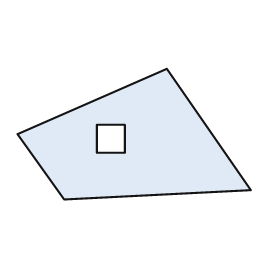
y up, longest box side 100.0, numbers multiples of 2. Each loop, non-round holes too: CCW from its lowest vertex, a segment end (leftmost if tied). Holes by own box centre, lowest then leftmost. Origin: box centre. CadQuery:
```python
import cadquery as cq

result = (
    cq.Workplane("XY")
    .moveTo(-30.0, -28.0)
    .lineTo(50.0, -24.0)
    .lineTo(14.0, 28.0)
    .lineTo(-50.0, 0.0)
    .close()
    .moveTo(-16.0, -8.0)
    .lineTo(-4.0, -8.0)
    .lineTo(-4.0, 4.0)
    .lineTo(-16.0, 4.0)
    .close()
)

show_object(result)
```